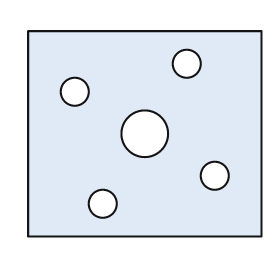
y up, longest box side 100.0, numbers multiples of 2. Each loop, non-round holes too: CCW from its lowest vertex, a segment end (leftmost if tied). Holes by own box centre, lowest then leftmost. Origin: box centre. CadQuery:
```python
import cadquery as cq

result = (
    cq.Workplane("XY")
    .moveTo(-50.0, -44.0)
    .lineTo(50.0, -44.0)
    .lineTo(50.0, 44.0)
    .lineTo(-50.0, 44.0)
    .close()
    .moveTo(-18.0, -30.0)
    .circle(6.0)
    .moveTo(30.0, -18.0)
    .circle(6.0)
    .moveTo(0.0, 0.0)
    .circle(10.0)
    .moveTo(-30.0, 18.0)
    .circle(6.0)
    .moveTo(18.0, 30.0)
    .circle(6.0)
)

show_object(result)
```